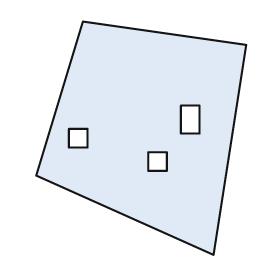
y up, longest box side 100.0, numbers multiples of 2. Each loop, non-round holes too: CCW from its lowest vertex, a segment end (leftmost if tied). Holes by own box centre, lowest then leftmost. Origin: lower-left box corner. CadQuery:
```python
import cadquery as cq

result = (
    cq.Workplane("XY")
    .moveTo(76.0, 0.0)
    .lineTo(90.0, 90.0)
    .lineTo(20.0, 100.0)
    .lineTo(0.0, 34.0)
    .close()
    .moveTo(48.0, 36.0)
    .lineTo(56.0, 36.0)
    .lineTo(56.0, 44.0)
    .lineTo(48.0, 44.0)
    .close()
    .moveTo(14.0, 46.0)
    .lineTo(22.0, 46.0)
    .lineTo(22.0, 54.0)
    .lineTo(14.0, 54.0)
    .close()
    .moveTo(62.0, 52.0)
    .lineTo(70.0, 52.0)
    .lineTo(70.0, 64.0)
    .lineTo(62.0, 64.0)
    .close()
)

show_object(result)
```